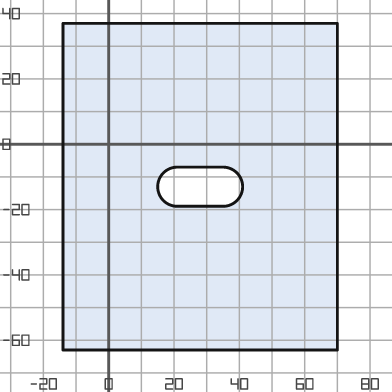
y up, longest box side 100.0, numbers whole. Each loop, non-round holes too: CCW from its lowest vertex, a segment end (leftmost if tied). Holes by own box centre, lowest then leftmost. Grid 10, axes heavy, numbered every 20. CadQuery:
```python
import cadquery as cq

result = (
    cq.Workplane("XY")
    .moveTo(-14.0, -63.0)
    .lineTo(70.0, -63.0)
    .lineTo(70.0, 37.0)
    .lineTo(-14.0, 37.0)
    .close()
    .moveTo(21.0, -19.0)
    .lineTo(35.0, -19.0)
    .threePointArc((41.0, -13.0), (35.0, -7.0))
    .lineTo(21.0, -7.0)
    .threePointArc((15.0, -13.0), (21.0, -19.0))
    .close()
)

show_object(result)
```